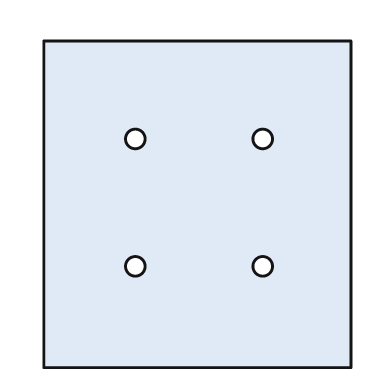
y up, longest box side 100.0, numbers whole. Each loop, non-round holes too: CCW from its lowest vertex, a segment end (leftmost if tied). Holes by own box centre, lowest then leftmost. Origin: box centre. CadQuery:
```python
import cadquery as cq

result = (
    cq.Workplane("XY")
    .moveTo(-47.0, -50.0)
    .lineTo(47.0, -50.0)
    .lineTo(47.0, 50.0)
    .lineTo(-47.0, 50.0)
    .close()
    .moveTo(-19.0, -19.0)
    .circle(3.0)
    .moveTo(20.0, -19.0)
    .circle(3.0)
    .moveTo(-19.0, 20.0)
    .circle(3.0)
    .moveTo(20.0, 20.0)
    .circle(3.0)
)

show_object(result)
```